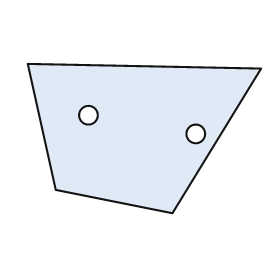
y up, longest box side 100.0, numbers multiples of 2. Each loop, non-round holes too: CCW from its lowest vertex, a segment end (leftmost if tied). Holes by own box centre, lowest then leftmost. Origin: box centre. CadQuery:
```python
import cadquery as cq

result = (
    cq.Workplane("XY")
    .moveTo(12.0, -32.0)
    .lineTo(50.0, 30.0)
    .lineTo(-50.0, 32.0)
    .lineTo(-38.0, -22.0)
    .close()
    .moveTo(22.0, 2.0)
    .circle(4.0)
    .moveTo(-24.0, 10.0)
    .circle(4.0)
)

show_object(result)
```